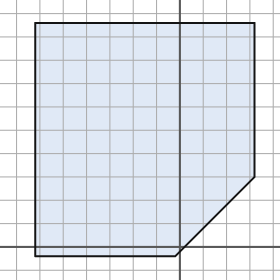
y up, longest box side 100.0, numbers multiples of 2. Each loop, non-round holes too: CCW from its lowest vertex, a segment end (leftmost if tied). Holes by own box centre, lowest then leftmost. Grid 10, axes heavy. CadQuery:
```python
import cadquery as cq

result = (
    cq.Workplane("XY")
    .moveTo(-62.0, -4.0)
    .lineTo(-2.0, -4.0)
    .lineTo(32.0, 30.0)
    .lineTo(32.0, 96.0)
    .lineTo(-62.0, 96.0)
    .close()
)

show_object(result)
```